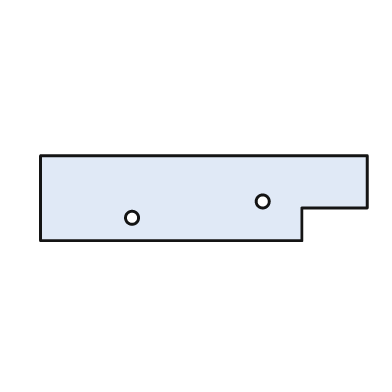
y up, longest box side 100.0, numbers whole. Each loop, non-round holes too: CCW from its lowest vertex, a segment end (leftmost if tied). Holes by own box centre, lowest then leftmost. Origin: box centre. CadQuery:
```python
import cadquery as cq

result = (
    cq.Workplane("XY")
    .moveTo(-50.0, -13.0)
    .lineTo(30.0, -13.0)
    .lineTo(30.0, -3.0)
    .lineTo(50.0, -3.0)
    .lineTo(50.0, 13.0)
    .lineTo(-50.0, 13.0)
    .close()
    .moveTo(-22.0, -6.0)
    .circle(2.0)
    .moveTo(18.0, -1.0)
    .circle(2.0)
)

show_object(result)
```